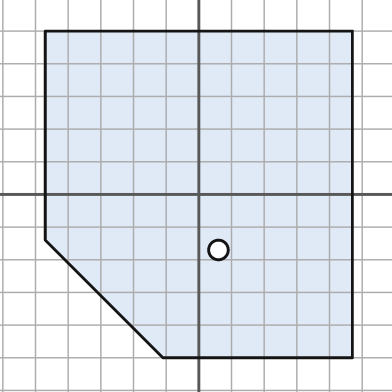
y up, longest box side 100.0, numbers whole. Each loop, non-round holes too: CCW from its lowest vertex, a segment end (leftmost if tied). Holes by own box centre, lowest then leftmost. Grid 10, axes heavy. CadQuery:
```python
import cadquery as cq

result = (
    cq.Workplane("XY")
    .moveTo(-11.0, -50.0)
    .lineTo(47.0, -50.0)
    .lineTo(47.0, 50.0)
    .lineTo(-47.0, 50.0)
    .lineTo(-47.0, -14.0)
    .close()
    .moveTo(6.0, -17.0)
    .circle(3.0)
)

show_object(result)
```